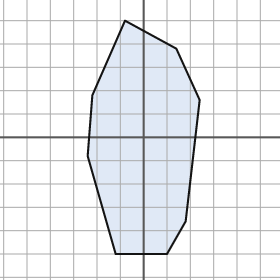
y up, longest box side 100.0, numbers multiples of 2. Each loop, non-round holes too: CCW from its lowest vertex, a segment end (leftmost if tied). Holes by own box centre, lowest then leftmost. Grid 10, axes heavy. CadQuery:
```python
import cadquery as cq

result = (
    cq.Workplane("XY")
    .moveTo(-12.0, -50.0)
    .lineTo(10.0, -50.0)
    .lineTo(18.0, -36.0)
    .lineTo(24.0, 16.0)
    .lineTo(14.0, 38.0)
    .lineTo(-8.0, 50.0)
    .lineTo(-22.0, 18.0)
    .lineTo(-24.0, -8.0)
    .close()
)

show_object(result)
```